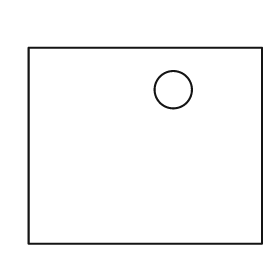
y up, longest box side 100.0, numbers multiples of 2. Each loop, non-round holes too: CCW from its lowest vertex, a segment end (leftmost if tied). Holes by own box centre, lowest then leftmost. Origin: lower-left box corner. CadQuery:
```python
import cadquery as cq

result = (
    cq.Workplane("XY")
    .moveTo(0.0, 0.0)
    .lineTo(100.0, 0.0)
    .lineTo(100.0, 84.0)
    .lineTo(0.0, 84.0)
    .close()
    .moveTo(62.0, 66.0)
    .circle(8.0)
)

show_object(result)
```